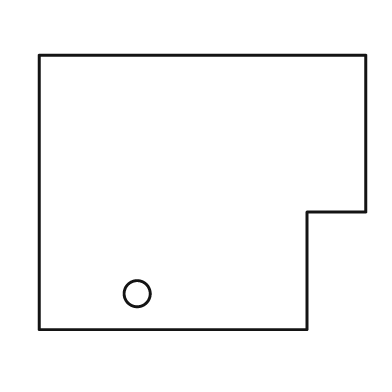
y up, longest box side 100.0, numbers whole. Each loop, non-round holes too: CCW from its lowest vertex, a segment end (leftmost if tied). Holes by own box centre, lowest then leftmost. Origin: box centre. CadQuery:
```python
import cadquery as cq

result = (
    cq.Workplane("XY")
    .moveTo(-50.0, -42.0)
    .lineTo(32.0, -42.0)
    .lineTo(32.0, -6.0)
    .lineTo(50.0, -6.0)
    .lineTo(50.0, 42.0)
    .lineTo(-50.0, 42.0)
    .close()
    .moveTo(-20.0, -31.0)
    .circle(4.0)
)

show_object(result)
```